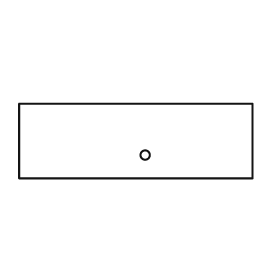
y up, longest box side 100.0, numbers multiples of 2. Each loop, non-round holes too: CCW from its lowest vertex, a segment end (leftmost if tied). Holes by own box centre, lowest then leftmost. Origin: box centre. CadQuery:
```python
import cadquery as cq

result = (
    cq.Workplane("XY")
    .moveTo(-50.0, -16.0)
    .lineTo(50.0, -16.0)
    .lineTo(50.0, 16.0)
    .lineTo(-50.0, 16.0)
    .close()
    .moveTo(4.0, -6.0)
    .circle(2.0)
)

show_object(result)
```